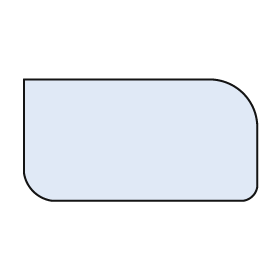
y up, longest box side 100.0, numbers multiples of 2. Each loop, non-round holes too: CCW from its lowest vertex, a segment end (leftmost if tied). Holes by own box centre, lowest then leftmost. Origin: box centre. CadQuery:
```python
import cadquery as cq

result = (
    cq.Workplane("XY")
    .moveTo(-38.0, -26.0)
    .lineTo(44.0, -26.0)
    .threePointArc((48.0, -24.0), (50.0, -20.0))
    .lineTo(50.0, 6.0)
    .threePointArc((44.0, 20.0), (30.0, 26.0))
    .lineTo(-50.0, 26.0)
    .lineTo(-50.0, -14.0)
    .threePointArc((-46.0, -22.0), (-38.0, -26.0))
    .close()
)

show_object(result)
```